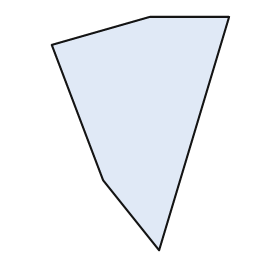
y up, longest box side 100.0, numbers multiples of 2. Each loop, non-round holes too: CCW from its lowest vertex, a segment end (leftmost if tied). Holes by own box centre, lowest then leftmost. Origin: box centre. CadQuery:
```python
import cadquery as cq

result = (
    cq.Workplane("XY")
    .moveTo(8.0, -50.0)
    .lineTo(38.0, 50.0)
    .lineTo(4.0, 50.0)
    .lineTo(-38.0, 38.0)
    .lineTo(-16.0, -20.0)
    .close()
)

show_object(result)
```